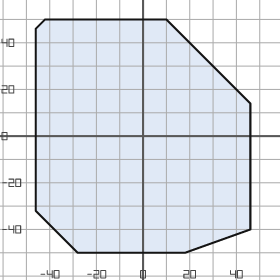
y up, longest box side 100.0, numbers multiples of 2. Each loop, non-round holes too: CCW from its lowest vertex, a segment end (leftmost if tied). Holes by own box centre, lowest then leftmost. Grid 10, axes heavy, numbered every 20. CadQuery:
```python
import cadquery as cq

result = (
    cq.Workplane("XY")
    .moveTo(-28.0, -50.0)
    .lineTo(18.0, -50.0)
    .lineTo(46.0, -40.0)
    .lineTo(46.0, 14.0)
    .lineTo(10.0, 50.0)
    .lineTo(-42.0, 50.0)
    .lineTo(-46.0, 46.0)
    .lineTo(-46.0, -32.0)
    .close()
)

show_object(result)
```